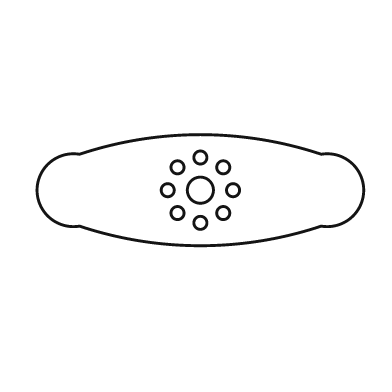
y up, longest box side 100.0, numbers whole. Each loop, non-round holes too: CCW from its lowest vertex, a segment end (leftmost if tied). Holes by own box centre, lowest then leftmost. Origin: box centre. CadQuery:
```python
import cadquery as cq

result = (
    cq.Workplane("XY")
    .moveTo(-37.0, -11.0)
    .threePointArc((0.0, -17.0), (37.0, -11.0))
    .threePointArc((50.0, 0.0), (37.0, 11.0))
    .threePointArc((0.0, 17.0), (-37.0, 11.0))
    .threePointArc((-50.0, 0.0), (-37.0, -11.0))
    .close()
    .moveTo(0.0, -10.0)
    .circle(2.0)
    .moveTo(-7.0, -7.0)
    .circle(2.0)
    .moveTo(7.0, -7.0)
    .circle(2.0)
    .moveTo(-10.0, 0.0)
    .circle(2.0)
    .moveTo(0.0, 0.0)
    .circle(4.0)
    .moveTo(10.0, 0.0)
    .circle(2.0)
    .moveTo(-7.0, 7.0)
    .circle(2.0)
    .moveTo(7.0, 7.0)
    .circle(2.0)
    .moveTo(0.0, 10.0)
    .circle(2.0)
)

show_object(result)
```